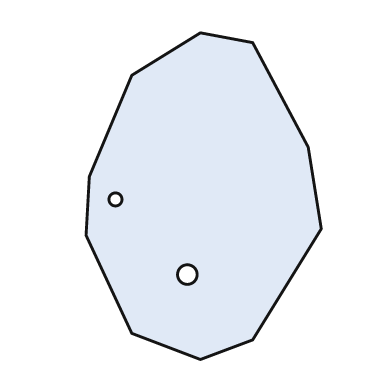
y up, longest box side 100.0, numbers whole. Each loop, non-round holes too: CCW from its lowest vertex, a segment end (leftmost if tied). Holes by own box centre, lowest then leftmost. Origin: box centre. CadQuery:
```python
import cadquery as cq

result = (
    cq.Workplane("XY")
    .moveTo(-1.0, -50.0)
    .lineTo(15.0, -44.0)
    .lineTo(36.0, -10.0)
    .lineTo(32.0, 15.0)
    .lineTo(15.0, 47.0)
    .lineTo(-1.0, 50.0)
    .lineTo(-22.0, 37.0)
    .lineTo(-35.0, 6.0)
    .lineTo(-36.0, -12.0)
    .lineTo(-22.0, -42.0)
    .close()
    .moveTo(-5.0, -24.0)
    .circle(3.0)
    .moveTo(-27.0, -1.0)
    .circle(2.0)
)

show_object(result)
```